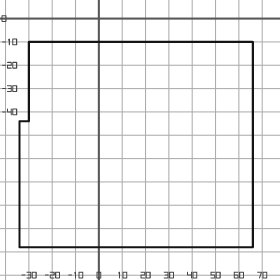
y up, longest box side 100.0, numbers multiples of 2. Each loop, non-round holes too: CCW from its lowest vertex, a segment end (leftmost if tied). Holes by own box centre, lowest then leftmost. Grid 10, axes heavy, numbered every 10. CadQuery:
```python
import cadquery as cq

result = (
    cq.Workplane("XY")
    .moveTo(-34.0, -98.0)
    .lineTo(66.0, -98.0)
    .lineTo(66.0, -10.0)
    .lineTo(-30.0, -10.0)
    .lineTo(-30.0, -44.0)
    .lineTo(-34.0, -44.0)
    .close()
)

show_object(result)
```